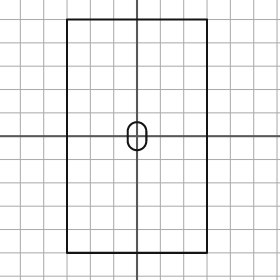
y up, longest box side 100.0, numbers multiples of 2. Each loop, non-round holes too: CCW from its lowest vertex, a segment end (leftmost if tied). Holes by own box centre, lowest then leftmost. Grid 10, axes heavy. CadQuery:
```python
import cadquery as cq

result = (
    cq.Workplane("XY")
    .moveTo(-30.0, -50.0)
    .lineTo(30.0, -50.0)
    .lineTo(30.0, 50.0)
    .lineTo(-30.0, 50.0)
    .close()
    .moveTo(-4.0, -2.0)
    .threePointArc((0.0, -6.0), (4.0, -2.0))
    .lineTo(4.0, 2.0)
    .threePointArc((0.0, 6.0), (-4.0, 2.0))
    .close()
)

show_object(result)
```